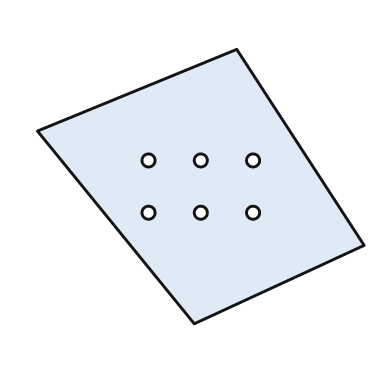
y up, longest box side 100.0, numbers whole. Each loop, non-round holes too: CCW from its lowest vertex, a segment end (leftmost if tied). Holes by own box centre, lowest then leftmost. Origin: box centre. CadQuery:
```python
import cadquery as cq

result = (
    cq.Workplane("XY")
    .moveTo(-2.0, -42.0)
    .lineTo(50.0, -18.0)
    .lineTo(11.0, 42.0)
    .lineTo(-50.0, 17.0)
    .close()
    .moveTo(-16.0, -8.0)
    .circle(2.0)
    .moveTo(0.0, -8.0)
    .circle(2.0)
    .moveTo(16.0, -8.0)
    .circle(2.0)
    .moveTo(-16.0, 8.0)
    .circle(2.0)
    .moveTo(0.0, 8.0)
    .circle(2.0)
    .moveTo(16.0, 8.0)
    .circle(2.0)
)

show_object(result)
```